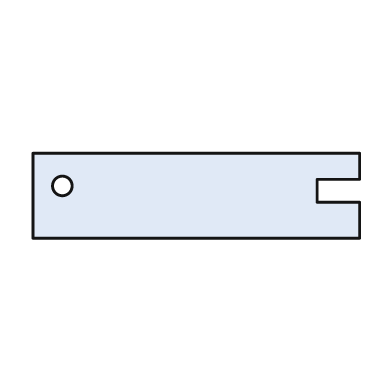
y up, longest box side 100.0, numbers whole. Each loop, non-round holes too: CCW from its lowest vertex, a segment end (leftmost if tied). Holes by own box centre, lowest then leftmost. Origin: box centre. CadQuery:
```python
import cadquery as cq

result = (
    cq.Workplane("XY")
    .moveTo(-50.0, -13.0)
    .lineTo(50.0, -13.0)
    .lineTo(50.0, -2.0)
    .lineTo(37.0, -2.0)
    .lineTo(37.0, 5.0)
    .lineTo(50.0, 5.0)
    .lineTo(50.0, 13.0)
    .lineTo(-50.0, 13.0)
    .close()
    .moveTo(-41.0, 3.0)
    .circle(3.0)
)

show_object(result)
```